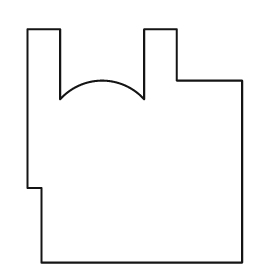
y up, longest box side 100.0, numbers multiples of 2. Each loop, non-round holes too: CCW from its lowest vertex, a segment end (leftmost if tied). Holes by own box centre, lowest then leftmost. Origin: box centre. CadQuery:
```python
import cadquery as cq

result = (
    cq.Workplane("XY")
    .moveTo(-40.0, -50.0)
    .lineTo(46.0, -50.0)
    .lineTo(46.0, 28.0)
    .lineTo(18.0, 28.0)
    .lineTo(18.0, 50.0)
    .lineTo(4.0, 50.0)
    .lineTo(4.0, 20.0)
    .threePointArc((-14.0, 28.0), (-32.0, 20.0))
    .lineTo(-32.0, 50.0)
    .lineTo(-46.0, 50.0)
    .lineTo(-46.0, -18.0)
    .lineTo(-40.0, -18.0)
    .close()
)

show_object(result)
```